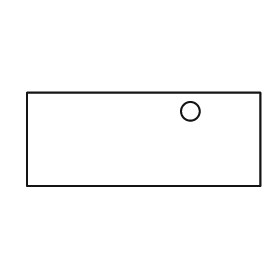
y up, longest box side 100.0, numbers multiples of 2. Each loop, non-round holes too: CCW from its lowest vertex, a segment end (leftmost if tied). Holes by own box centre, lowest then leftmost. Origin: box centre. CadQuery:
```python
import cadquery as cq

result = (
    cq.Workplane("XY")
    .moveTo(-50.0, -20.0)
    .lineTo(50.0, -20.0)
    .lineTo(50.0, 20.0)
    .lineTo(-50.0, 20.0)
    .close()
    .moveTo(20.0, 12.0)
    .circle(4.0)
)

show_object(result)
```